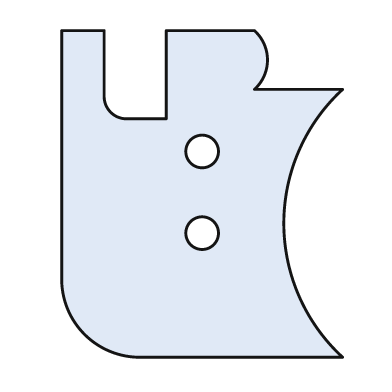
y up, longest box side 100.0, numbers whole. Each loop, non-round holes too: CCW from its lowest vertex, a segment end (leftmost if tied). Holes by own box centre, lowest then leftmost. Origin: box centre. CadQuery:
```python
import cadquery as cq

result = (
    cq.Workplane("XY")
    .moveTo(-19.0, -50.0)
    .lineTo(43.0, -50.0)
    .threePointArc((25.0, -9.0), (43.0, 32.0))
    .lineTo(16.0, 32.0)
    .threePointArc((20.0, 41.0), (16.0, 50.0))
    .lineTo(-11.0, 50.0)
    .lineTo(-11.0, 23.0)
    .lineTo(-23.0, 23.0)
    .threePointArc((-28.0, 25.0), (-30.0, 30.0))
    .lineTo(-30.0, 50.0)
    .lineTo(-43.0, 50.0)
    .lineTo(-43.0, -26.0)
    .threePointArc((-36.0, -43.0), (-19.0, -50.0))
    .close()
    .moveTo(0.0, -12.0)
    .circle(5.0)
    .moveTo(0.0, 13.0)
    .circle(5.0)
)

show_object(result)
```